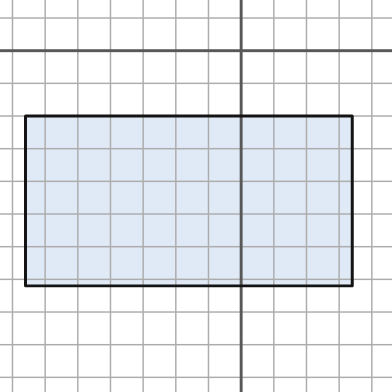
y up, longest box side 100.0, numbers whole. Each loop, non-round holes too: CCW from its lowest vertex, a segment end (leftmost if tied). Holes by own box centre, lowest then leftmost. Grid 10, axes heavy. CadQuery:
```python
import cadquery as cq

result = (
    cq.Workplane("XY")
    .moveTo(-66.0, -72.0)
    .lineTo(34.0, -72.0)
    .lineTo(34.0, -20.0)
    .lineTo(-66.0, -20.0)
    .close()
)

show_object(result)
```